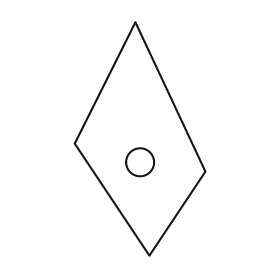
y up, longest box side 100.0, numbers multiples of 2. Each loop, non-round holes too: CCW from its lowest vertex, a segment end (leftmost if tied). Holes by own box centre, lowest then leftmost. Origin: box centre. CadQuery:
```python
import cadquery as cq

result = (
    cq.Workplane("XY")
    .moveTo(4.0, -50.0)
    .lineTo(28.0, -14.0)
    .lineTo(-2.0, 50.0)
    .lineTo(-28.0, -2.0)
    .close()
    .moveTo(0.0, -10.0)
    .circle(6.0)
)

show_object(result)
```